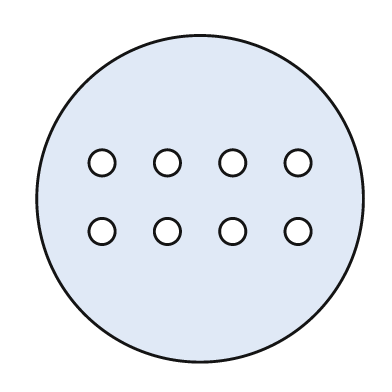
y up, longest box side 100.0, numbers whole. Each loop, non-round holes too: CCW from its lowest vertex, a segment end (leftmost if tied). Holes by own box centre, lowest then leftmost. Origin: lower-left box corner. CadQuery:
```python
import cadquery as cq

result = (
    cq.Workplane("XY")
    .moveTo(50.0, 50.0)
    .circle(50.0)
    .moveTo(20.0, 40.0)
    .circle(4.0)
    .moveTo(40.0, 40.0)
    .circle(4.0)
    .moveTo(60.0, 40.0)
    .circle(4.0)
    .moveTo(80.0, 40.0)
    .circle(4.0)
    .moveTo(20.0, 61.0)
    .circle(4.0)
    .moveTo(40.0, 61.0)
    .circle(4.0)
    .moveTo(60.0, 61.0)
    .circle(4.0)
    .moveTo(80.0, 61.0)
    .circle(4.0)
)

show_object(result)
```